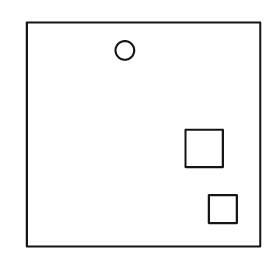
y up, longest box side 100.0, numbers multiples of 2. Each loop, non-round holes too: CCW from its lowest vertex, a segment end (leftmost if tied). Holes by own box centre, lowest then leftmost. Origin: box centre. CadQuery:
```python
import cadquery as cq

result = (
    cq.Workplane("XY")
    .moveTo(-50.0, -48.0)
    .lineTo(50.0, -48.0)
    .lineTo(50.0, 48.0)
    .lineTo(-50.0, 48.0)
    .close()
    .moveTo(28.0, -38.0)
    .lineTo(40.0, -38.0)
    .lineTo(40.0, -26.0)
    .lineTo(28.0, -26.0)
    .close()
    .moveTo(18.0, -14.0)
    .lineTo(34.0, -14.0)
    .lineTo(34.0, 2.0)
    .lineTo(18.0, 2.0)
    .close()
    .moveTo(-8.0, 36.0)
    .circle(4.0)
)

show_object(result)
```